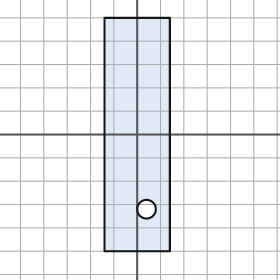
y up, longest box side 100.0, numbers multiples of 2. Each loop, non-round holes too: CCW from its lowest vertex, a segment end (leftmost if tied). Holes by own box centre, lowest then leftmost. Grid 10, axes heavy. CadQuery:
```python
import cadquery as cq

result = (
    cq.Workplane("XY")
    .moveTo(-14.0, -50.0)
    .lineTo(14.0, -50.0)
    .lineTo(14.0, 50.0)
    .lineTo(-14.0, 50.0)
    .close()
    .moveTo(4.0, -32.0)
    .circle(4.0)
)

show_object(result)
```